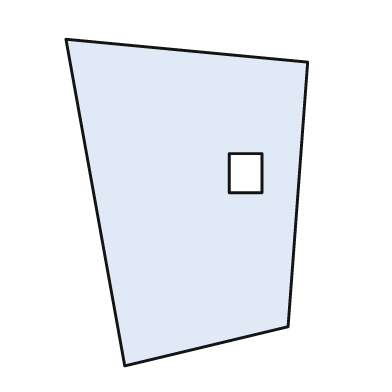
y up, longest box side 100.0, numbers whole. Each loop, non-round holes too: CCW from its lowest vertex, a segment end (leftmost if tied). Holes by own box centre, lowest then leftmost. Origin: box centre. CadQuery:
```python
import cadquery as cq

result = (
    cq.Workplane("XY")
    .moveTo(-19.0, -50.0)
    .lineTo(31.0, -38.0)
    .lineTo(37.0, 43.0)
    .lineTo(-37.0, 50.0)
    .close()
    .moveTo(13.0, 3.0)
    .lineTo(23.0, 3.0)
    .lineTo(23.0, 15.0)
    .lineTo(13.0, 15.0)
    .close()
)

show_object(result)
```